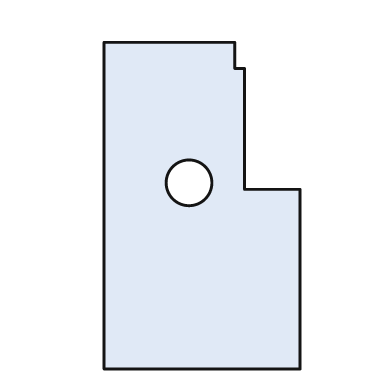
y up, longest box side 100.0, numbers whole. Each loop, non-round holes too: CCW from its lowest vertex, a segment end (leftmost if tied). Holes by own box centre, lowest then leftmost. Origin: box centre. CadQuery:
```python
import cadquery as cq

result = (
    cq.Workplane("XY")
    .moveTo(-30.0, -50.0)
    .lineTo(30.0, -50.0)
    .lineTo(30.0, 5.0)
    .lineTo(13.0, 5.0)
    .lineTo(13.0, 42.0)
    .lineTo(10.0, 42.0)
    .lineTo(10.0, 50.0)
    .lineTo(-30.0, 50.0)
    .close()
    .moveTo(-4.0, 7.0)
    .circle(7.0)
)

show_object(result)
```